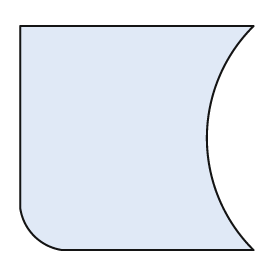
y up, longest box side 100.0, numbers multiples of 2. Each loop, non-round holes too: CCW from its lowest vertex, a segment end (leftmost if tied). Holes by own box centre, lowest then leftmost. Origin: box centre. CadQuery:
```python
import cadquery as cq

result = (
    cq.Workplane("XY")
    .moveTo(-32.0, -48.0)
    .lineTo(50.0, -48.0)
    .threePointArc((30.0, 0.0), (50.0, 48.0))
    .lineTo(-50.0, 48.0)
    .lineTo(-50.0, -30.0)
    .threePointArc((-44.0, -42.0), (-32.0, -48.0))
    .close()
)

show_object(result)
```